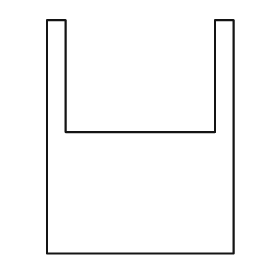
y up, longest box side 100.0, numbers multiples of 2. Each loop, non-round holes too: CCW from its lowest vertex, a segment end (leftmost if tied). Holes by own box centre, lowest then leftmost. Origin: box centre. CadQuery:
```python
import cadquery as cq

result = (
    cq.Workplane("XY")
    .moveTo(-40.0, -50.0)
    .lineTo(40.0, -50.0)
    .lineTo(40.0, 50.0)
    .lineTo(32.0, 50.0)
    .lineTo(32.0, 2.0)
    .lineTo(-32.0, 2.0)
    .lineTo(-32.0, 50.0)
    .lineTo(-40.0, 50.0)
    .close()
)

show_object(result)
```